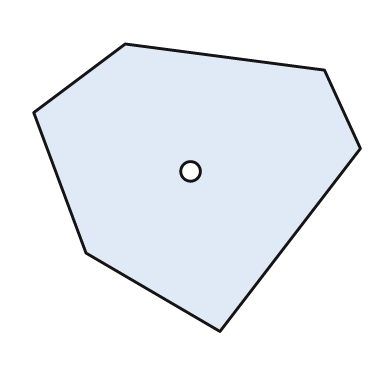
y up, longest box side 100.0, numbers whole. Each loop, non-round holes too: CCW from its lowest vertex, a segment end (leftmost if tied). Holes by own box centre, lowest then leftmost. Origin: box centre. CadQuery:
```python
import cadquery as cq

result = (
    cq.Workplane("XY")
    .moveTo(7.0, -44.0)
    .lineTo(50.0, 12.0)
    .lineTo(39.0, 36.0)
    .lineTo(-22.0, 44.0)
    .lineTo(-50.0, 23.0)
    .lineTo(-34.0, -20.0)
    .close()
    .moveTo(-2.0, 5.0)
    .circle(3.0)
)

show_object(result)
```